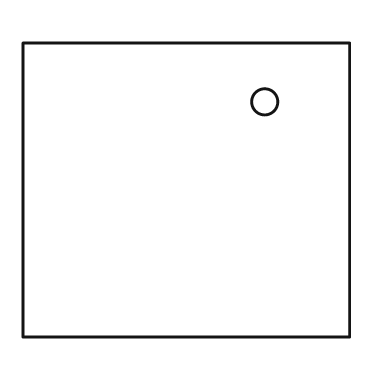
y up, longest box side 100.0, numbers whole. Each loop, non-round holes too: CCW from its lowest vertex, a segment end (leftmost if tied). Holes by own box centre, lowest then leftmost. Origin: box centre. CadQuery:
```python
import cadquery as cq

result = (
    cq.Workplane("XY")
    .moveTo(-50.0, -45.0)
    .lineTo(50.0, -45.0)
    .lineTo(50.0, 45.0)
    .lineTo(-50.0, 45.0)
    .close()
    .moveTo(24.0, 27.0)
    .circle(4.0)
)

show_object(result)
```